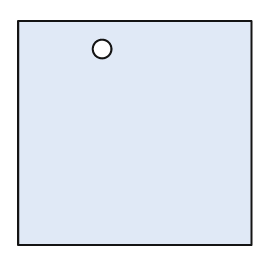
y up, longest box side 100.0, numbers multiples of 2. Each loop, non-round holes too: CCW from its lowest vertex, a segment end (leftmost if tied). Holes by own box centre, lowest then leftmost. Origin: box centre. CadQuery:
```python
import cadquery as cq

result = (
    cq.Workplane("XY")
    .moveTo(-50.0, -48.0)
    .lineTo(50.0, -48.0)
    .lineTo(50.0, 48.0)
    .lineTo(-50.0, 48.0)
    .close()
    .moveTo(-14.0, 36.0)
    .circle(4.0)
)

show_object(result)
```